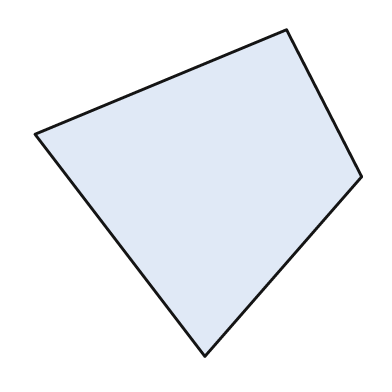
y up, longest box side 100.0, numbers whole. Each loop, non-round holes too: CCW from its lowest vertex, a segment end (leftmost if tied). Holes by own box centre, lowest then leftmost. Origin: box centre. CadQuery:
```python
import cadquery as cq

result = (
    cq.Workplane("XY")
    .moveTo(2.0, -50.0)
    .lineTo(50.0, 5.0)
    .lineTo(27.0, 50.0)
    .lineTo(-50.0, 18.0)
    .close()
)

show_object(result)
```